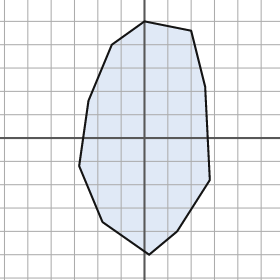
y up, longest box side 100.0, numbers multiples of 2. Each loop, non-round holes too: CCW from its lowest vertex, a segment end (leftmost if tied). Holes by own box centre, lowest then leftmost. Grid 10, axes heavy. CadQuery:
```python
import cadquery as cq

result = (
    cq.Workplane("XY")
    .moveTo(2.0, -50.0)
    .lineTo(14.0, -40.0)
    .lineTo(28.0, -18.0)
    .lineTo(26.0, 22.0)
    .lineTo(20.0, 46.0)
    .lineTo(0.0, 50.0)
    .lineTo(-14.0, 40.0)
    .lineTo(-24.0, 16.0)
    .lineTo(-28.0, -12.0)
    .lineTo(-18.0, -36.0)
    .close()
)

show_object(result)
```